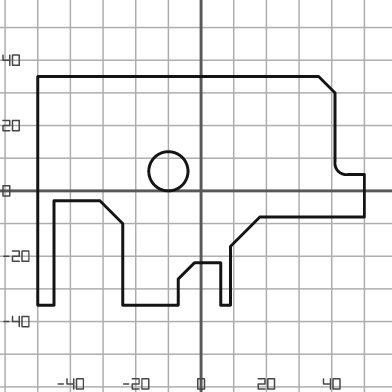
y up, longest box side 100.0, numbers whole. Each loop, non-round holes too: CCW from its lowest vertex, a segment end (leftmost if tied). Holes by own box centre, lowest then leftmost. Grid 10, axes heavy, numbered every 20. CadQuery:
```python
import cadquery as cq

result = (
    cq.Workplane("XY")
    .moveTo(-50.0, -35.0)
    .lineTo(-45.0, -35.0)
    .lineTo(-45.0, -3.0)
    .lineTo(-31.0, -3.0)
    .lineTo(-24.0, -10.0)
    .lineTo(-24.0, -35.0)
    .lineTo(-7.0, -35.0)
    .lineTo(-7.0, -27.0)
    .lineTo(-2.0, -22.0)
    .lineTo(6.0, -22.0)
    .lineTo(6.0, -35.0)
    .lineTo(9.0, -35.0)
    .lineTo(9.0, -17.0)
    .lineTo(18.0, -8.0)
    .lineTo(50.0, -8.0)
    .lineTo(50.0, 5.0)
    .lineTo(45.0, 5.0)
    .threePointArc((42.0, 6.0), (41.0, 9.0))
    .lineTo(41.0, 30.0)
    .lineTo(36.0, 35.0)
    .lineTo(-50.0, 35.0)
    .close()
    .moveTo(-10.0, 6.0)
    .circle(6.0)
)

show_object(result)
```